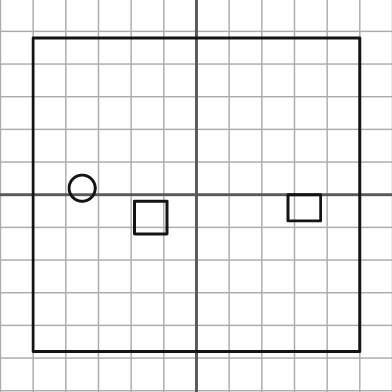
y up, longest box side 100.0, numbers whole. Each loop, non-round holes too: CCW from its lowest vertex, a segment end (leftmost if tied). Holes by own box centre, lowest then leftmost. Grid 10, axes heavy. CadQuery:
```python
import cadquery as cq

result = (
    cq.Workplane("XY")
    .moveTo(-50.0, -48.0)
    .lineTo(50.0, -48.0)
    .lineTo(50.0, 48.0)
    .lineTo(-50.0, 48.0)
    .close()
    .moveTo(-19.0, -12.0)
    .lineTo(-9.0, -12.0)
    .lineTo(-9.0, -2.0)
    .lineTo(-19.0, -2.0)
    .close()
    .moveTo(28.0, -8.0)
    .lineTo(38.0, -8.0)
    .lineTo(38.0, 0.0)
    .lineTo(28.0, 0.0)
    .close()
    .moveTo(-35.0, 2.0)
    .circle(4.0)
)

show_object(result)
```